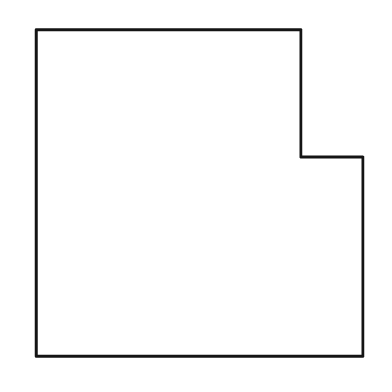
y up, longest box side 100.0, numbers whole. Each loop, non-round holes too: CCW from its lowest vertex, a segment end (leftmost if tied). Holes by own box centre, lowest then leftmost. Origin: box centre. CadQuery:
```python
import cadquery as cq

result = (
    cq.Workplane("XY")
    .moveTo(-50.0, -50.0)
    .lineTo(50.0, -50.0)
    .lineTo(50.0, 11.0)
    .lineTo(31.0, 11.0)
    .lineTo(31.0, 50.0)
    .lineTo(-50.0, 50.0)
    .close()
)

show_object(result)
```